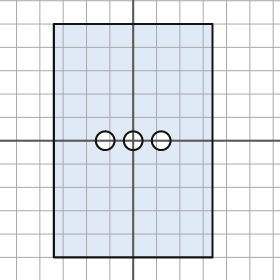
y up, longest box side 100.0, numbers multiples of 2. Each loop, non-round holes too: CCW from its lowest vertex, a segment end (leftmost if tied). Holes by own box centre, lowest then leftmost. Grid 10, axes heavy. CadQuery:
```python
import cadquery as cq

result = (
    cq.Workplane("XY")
    .moveTo(-34.0, -50.0)
    .lineTo(34.0, -50.0)
    .lineTo(34.0, 50.0)
    .lineTo(-34.0, 50.0)
    .close()
    .moveTo(-12.0, 0.0)
    .circle(4.0)
    .moveTo(0.0, 0.0)
    .circle(4.0)
    .moveTo(12.0, 0.0)
    .circle(4.0)
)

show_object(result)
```